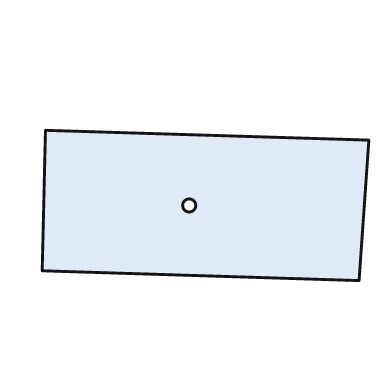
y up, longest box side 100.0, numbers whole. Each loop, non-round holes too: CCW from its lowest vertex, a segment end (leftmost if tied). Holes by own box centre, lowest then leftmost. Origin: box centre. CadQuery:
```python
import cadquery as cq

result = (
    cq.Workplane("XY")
    .moveTo(47.0, -23.0)
    .lineTo(50.0, 20.0)
    .lineTo(-49.0, 23.0)
    .lineTo(-50.0, -20.0)
    .close()
    .moveTo(-5.0, 0.0)
    .circle(2.0)
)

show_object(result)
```